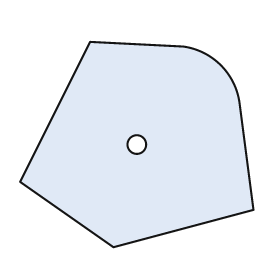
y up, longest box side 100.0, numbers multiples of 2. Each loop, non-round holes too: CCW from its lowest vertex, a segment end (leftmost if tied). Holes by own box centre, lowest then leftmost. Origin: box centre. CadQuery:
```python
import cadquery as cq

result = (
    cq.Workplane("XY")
    .moveTo(-10.0, -44.0)
    .lineTo(50.0, -28.0)
    .lineTo(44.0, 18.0)
    .threePointArc((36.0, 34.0), (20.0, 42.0))
    .lineTo(-20.0, 44.0)
    .lineTo(-50.0, -16.0)
    .close()
    .moveTo(0.0, 0.0)
    .circle(4.0)
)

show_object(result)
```